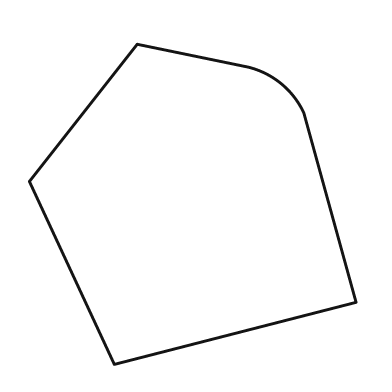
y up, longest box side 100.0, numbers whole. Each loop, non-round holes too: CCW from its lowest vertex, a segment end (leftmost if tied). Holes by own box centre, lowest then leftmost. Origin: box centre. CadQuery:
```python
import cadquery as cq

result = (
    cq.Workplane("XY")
    .moveTo(-24.0, -49.0)
    .lineTo(50.0, -30.0)
    .lineTo(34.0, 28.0)
    .threePointArc((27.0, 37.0), (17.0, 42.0))
    .lineTo(-17.0, 49.0)
    .lineTo(-50.0, 7.0)
    .close()
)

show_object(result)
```